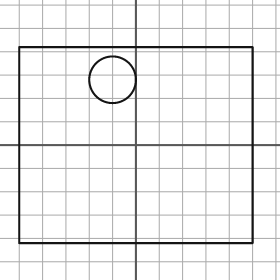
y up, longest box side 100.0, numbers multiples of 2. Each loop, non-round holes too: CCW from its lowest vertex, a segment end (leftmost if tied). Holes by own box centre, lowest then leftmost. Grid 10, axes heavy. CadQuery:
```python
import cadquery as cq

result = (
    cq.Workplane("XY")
    .moveTo(-50.0, -42.0)
    .lineTo(50.0, -42.0)
    .lineTo(50.0, 42.0)
    .lineTo(-50.0, 42.0)
    .close()
    .moveTo(-10.0, 28.0)
    .circle(10.0)
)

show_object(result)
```